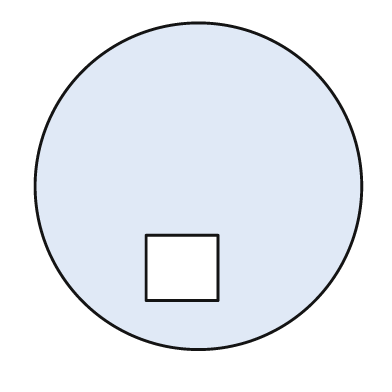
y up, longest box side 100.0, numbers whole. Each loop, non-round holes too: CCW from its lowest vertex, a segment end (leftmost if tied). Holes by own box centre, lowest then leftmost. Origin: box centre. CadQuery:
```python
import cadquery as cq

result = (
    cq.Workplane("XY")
    .moveTo(0.0, 0.0)
    .circle(50.0)
    .moveTo(-16.0, -35.0)
    .lineTo(6.0, -35.0)
    .lineTo(6.0, -15.0)
    .lineTo(-16.0, -15.0)
    .close()
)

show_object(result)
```